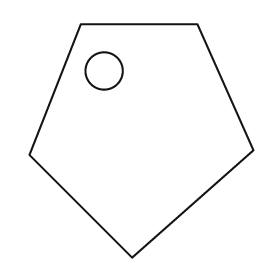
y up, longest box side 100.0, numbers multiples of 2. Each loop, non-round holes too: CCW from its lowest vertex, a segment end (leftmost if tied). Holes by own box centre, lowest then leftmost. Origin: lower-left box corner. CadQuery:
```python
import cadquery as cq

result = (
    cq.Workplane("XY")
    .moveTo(44.0, 0.0)
    .lineTo(96.0, 46.0)
    .lineTo(72.0, 100.0)
    .lineTo(22.0, 100.0)
    .lineTo(0.0, 44.0)
    .close()
    .moveTo(32.0, 80.0)
    .circle(8.0)
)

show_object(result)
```